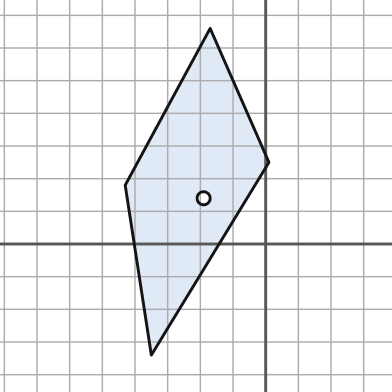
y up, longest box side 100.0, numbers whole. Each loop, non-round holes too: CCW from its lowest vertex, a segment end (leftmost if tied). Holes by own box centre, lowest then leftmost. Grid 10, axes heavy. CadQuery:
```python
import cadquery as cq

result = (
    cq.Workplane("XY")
    .moveTo(-35.0, -34.0)
    .lineTo(1.0, 25.0)
    .lineTo(-17.0, 66.0)
    .lineTo(-43.0, 18.0)
    .close()
    .moveTo(-19.0, 14.0)
    .circle(2.0)
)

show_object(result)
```